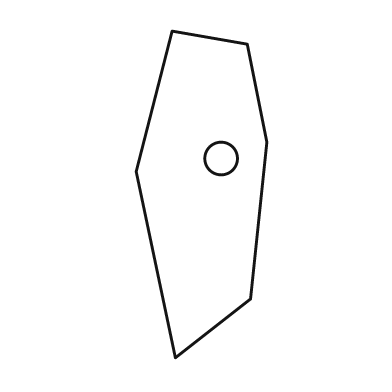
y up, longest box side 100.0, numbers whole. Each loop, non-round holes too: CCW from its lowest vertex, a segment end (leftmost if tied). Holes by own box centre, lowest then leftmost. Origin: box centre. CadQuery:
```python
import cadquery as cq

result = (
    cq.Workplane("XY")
    .moveTo(-8.0, -50.0)
    .lineTo(15.0, -32.0)
    .lineTo(20.0, 16.0)
    .lineTo(14.0, 46.0)
    .lineTo(-9.0, 50.0)
    .lineTo(-20.0, 7.0)
    .close()
    .moveTo(6.0, 11.0)
    .circle(5.0)
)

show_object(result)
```